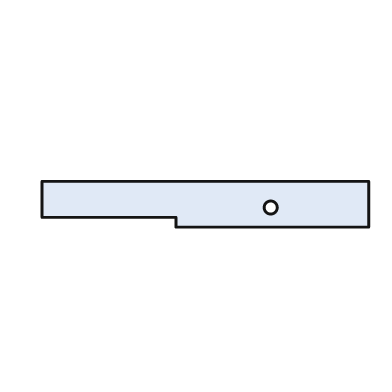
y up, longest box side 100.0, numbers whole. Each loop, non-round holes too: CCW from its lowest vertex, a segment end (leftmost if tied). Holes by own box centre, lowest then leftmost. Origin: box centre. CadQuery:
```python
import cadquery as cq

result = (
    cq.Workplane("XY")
    .moveTo(-9.0, -7.0)
    .lineTo(50.0, -7.0)
    .lineTo(50.0, 7.0)
    .lineTo(-50.0, 7.0)
    .lineTo(-50.0, -4.0)
    .lineTo(-9.0, -4.0)
    .close()
    .moveTo(20.0, -1.0)
    .circle(2.0)
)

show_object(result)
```